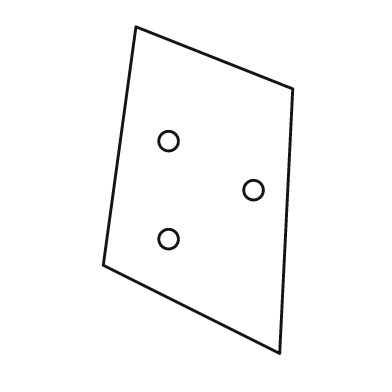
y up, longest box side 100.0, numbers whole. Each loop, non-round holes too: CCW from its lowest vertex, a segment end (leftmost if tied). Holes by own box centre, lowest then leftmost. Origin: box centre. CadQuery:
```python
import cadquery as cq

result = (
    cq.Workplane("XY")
    .moveTo(25.0, -50.0)
    .lineTo(29.0, 31.0)
    .lineTo(-19.0, 50.0)
    .lineTo(-29.0, -23.0)
    .close()
    .moveTo(-9.0, -15.0)
    .circle(3.0)
    .moveTo(17.0, 0.0)
    .circle(3.0)
    .moveTo(-9.0, 15.0)
    .circle(3.0)
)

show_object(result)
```